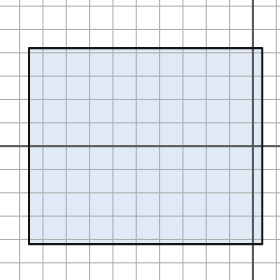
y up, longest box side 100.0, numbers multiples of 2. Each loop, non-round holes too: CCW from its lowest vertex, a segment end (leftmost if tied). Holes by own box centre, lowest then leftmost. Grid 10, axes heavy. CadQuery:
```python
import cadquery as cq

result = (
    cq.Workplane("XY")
    .moveTo(-96.0, -42.0)
    .lineTo(4.0, -42.0)
    .lineTo(4.0, 42.0)
    .lineTo(-96.0, 42.0)
    .close()
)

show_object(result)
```